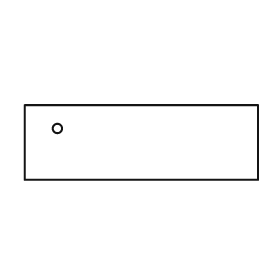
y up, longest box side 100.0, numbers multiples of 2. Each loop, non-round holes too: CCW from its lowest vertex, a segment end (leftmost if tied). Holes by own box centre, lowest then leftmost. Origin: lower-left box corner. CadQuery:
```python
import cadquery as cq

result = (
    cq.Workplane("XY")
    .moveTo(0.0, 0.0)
    .lineTo(100.0, 0.0)
    .lineTo(100.0, 32.0)
    .lineTo(0.0, 32.0)
    .close()
    .moveTo(14.0, 22.0)
    .circle(2.0)
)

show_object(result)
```